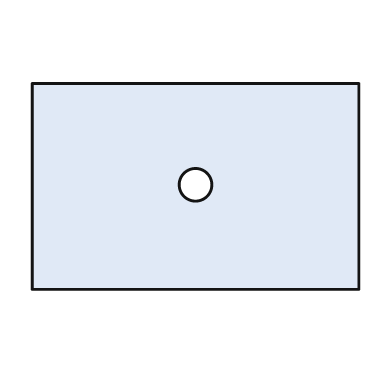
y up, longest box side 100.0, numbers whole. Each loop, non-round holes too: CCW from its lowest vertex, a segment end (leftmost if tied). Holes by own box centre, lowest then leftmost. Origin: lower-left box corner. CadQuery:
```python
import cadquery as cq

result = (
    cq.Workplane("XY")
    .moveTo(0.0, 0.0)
    .lineTo(100.0, 0.0)
    .lineTo(100.0, 63.0)
    .lineTo(0.0, 63.0)
    .close()
    .moveTo(50.0, 32.0)
    .circle(5.0)
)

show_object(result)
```